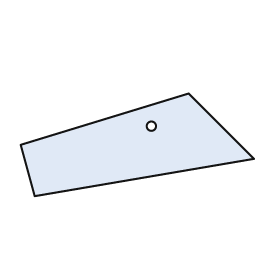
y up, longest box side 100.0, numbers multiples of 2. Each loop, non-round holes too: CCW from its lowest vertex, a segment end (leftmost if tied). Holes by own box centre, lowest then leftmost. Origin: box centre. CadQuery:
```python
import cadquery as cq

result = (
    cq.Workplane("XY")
    .moveTo(-44.0, -22.0)
    .lineTo(50.0, -6.0)
    .lineTo(22.0, 22.0)
    .lineTo(-50.0, 0.0)
    .close()
    .moveTo(6.0, 8.0)
    .circle(2.0)
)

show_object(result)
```